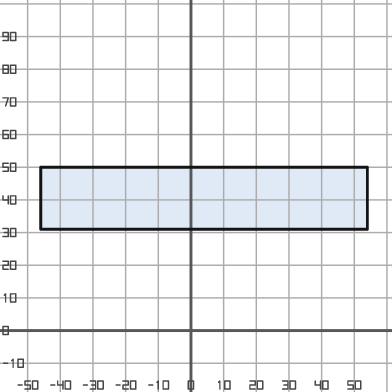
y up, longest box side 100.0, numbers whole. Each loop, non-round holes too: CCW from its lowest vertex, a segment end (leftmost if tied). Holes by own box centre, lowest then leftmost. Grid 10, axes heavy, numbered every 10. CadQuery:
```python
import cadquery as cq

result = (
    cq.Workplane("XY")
    .moveTo(-46.0, 31.0)
    .lineTo(54.0, 31.0)
    .lineTo(54.0, 50.0)
    .lineTo(-46.0, 50.0)
    .close()
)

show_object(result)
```